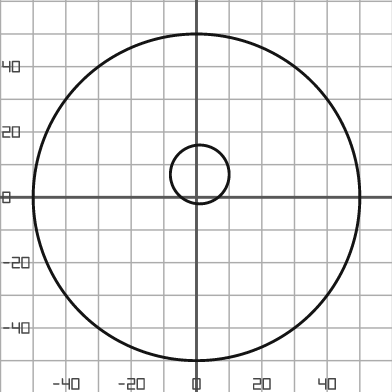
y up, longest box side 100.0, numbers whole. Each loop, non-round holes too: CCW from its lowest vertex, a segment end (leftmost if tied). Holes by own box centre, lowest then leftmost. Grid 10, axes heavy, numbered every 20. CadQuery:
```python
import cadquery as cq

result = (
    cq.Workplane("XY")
    .moveTo(0.0, 0.0)
    .circle(50.0)
    .moveTo(1.0, 7.0)
    .circle(9.0)
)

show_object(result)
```